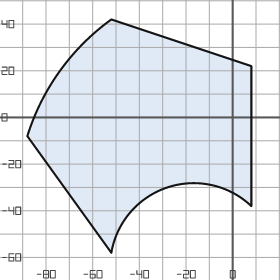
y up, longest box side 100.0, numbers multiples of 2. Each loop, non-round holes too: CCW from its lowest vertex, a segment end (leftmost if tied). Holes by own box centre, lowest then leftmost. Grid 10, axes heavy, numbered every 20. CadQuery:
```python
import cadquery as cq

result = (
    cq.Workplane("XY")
    .moveTo(-52.0, -58.0)
    .threePointArc((-28.0, -30.0), (8.0, -38.0))
    .lineTo(8.0, 22.0)
    .lineTo(-52.0, 42.0)
    .threePointArc((-74.0, 20.0), (-88.0, -8.0))
    .close()
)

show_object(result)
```